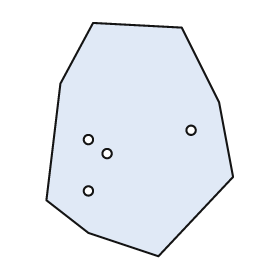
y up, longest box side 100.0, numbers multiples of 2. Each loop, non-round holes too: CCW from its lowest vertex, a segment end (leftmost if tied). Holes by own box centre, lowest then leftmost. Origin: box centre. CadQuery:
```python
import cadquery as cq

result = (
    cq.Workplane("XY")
    .moveTo(8.0, -50.0)
    .lineTo(40.0, -16.0)
    .lineTo(34.0, 16.0)
    .lineTo(18.0, 48.0)
    .lineTo(-20.0, 50.0)
    .lineTo(-34.0, 24.0)
    .lineTo(-40.0, -26.0)
    .lineTo(-22.0, -40.0)
    .close()
    .moveTo(-22.0, -22.0)
    .circle(2.0)
    .moveTo(-14.0, -6.0)
    .circle(2.0)
    .moveTo(-22.0, 0.0)
    .circle(2.0)
    .moveTo(22.0, 4.0)
    .circle(2.0)
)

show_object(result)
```